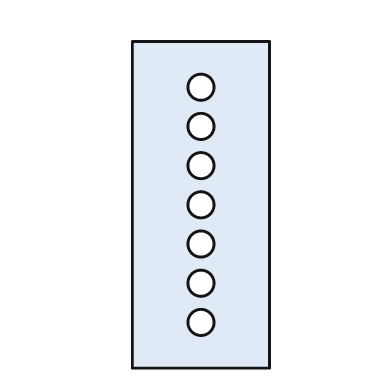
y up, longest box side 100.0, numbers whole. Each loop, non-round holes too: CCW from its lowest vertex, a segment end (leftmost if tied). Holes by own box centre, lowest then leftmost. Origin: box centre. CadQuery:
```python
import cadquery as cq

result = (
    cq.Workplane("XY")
    .moveTo(-21.0, -50.0)
    .lineTo(21.0, -50.0)
    .lineTo(21.0, 50.0)
    .lineTo(-21.0, 50.0)
    .close()
    .moveTo(0.0, -36.0)
    .circle(4.0)
    .moveTo(0.0, -24.0)
    .circle(4.0)
    .moveTo(0.0, -12.0)
    .circle(4.0)
    .moveTo(0.0, 0.0)
    .circle(4.0)
    .moveTo(0.0, 12.0)
    .circle(4.0)
    .moveTo(0.0, 24.0)
    .circle(4.0)
    .moveTo(0.0, 36.0)
    .circle(4.0)
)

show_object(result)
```